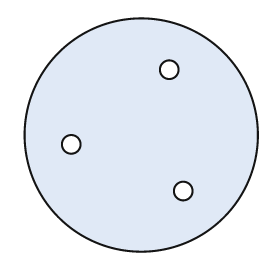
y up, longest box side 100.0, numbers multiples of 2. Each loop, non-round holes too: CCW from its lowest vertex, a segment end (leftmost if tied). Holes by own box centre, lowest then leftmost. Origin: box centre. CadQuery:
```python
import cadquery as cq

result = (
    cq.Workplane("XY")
    .moveTo(0.0, 0.0)
    .circle(50.0)
    .moveTo(18.0, -24.0)
    .circle(4.0)
    .moveTo(-30.0, -4.0)
    .circle(4.0)
    .moveTo(12.0, 28.0)
    .circle(4.0)
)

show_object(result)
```